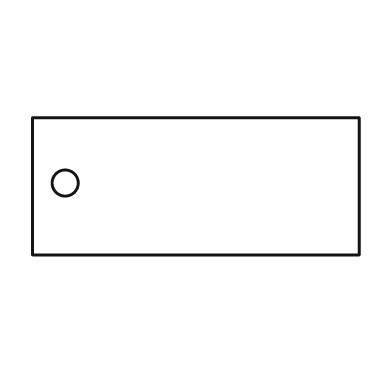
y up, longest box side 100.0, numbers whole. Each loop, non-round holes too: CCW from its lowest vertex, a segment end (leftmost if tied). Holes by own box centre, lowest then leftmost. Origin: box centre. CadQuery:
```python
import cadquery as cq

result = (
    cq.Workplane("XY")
    .moveTo(-50.0, -21.0)
    .lineTo(50.0, -21.0)
    .lineTo(50.0, 21.0)
    .lineTo(-50.0, 21.0)
    .close()
    .moveTo(-40.0, 1.0)
    .circle(4.0)
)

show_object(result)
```